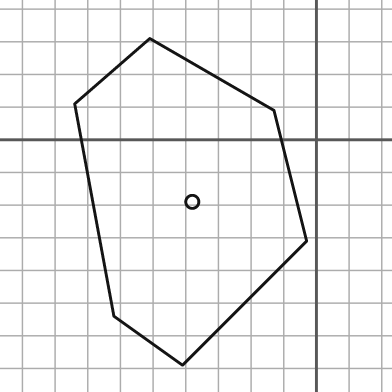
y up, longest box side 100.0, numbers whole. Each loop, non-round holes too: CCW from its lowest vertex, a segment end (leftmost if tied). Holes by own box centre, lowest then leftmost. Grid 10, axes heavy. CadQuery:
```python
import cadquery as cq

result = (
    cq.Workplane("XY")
    .moveTo(-41.0, -69.0)
    .lineTo(-3.0, -31.0)
    .lineTo(-13.0, 9.0)
    .lineTo(-51.0, 31.0)
    .lineTo(-74.0, 11.0)
    .lineTo(-62.0, -54.0)
    .close()
    .moveTo(-38.0, -19.0)
    .circle(2.0)
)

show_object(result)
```